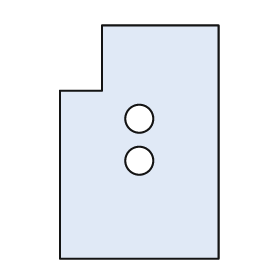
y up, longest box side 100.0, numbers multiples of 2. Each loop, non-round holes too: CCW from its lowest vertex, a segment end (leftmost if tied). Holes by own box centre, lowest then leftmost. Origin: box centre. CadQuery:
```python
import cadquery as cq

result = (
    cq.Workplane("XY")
    .moveTo(-34.0, -50.0)
    .lineTo(34.0, -50.0)
    .lineTo(34.0, 50.0)
    .lineTo(-16.0, 50.0)
    .lineTo(-16.0, 22.0)
    .lineTo(-34.0, 22.0)
    .close()
    .moveTo(0.0, -8.0)
    .circle(6.0)
    .moveTo(0.0, 10.0)
    .circle(6.0)
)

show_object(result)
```